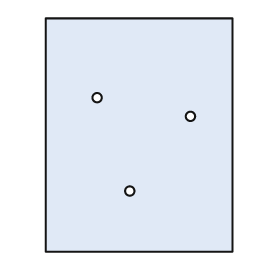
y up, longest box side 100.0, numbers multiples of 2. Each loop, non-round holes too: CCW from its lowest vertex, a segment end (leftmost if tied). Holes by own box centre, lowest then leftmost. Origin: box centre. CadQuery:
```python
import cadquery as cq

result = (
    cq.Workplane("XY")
    .moveTo(-40.0, -50.0)
    .lineTo(40.0, -50.0)
    .lineTo(40.0, 50.0)
    .lineTo(-40.0, 50.0)
    .close()
    .moveTo(-4.0, -24.0)
    .circle(2.0)
    .moveTo(22.0, 8.0)
    .circle(2.0)
    .moveTo(-18.0, 16.0)
    .circle(2.0)
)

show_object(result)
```